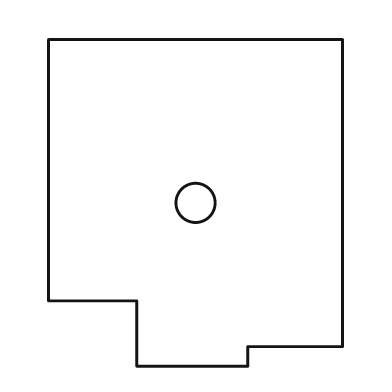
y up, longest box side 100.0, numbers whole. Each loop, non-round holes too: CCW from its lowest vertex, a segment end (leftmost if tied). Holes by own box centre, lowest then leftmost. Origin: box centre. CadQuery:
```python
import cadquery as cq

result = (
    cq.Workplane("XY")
    .moveTo(-18.0, -50.0)
    .lineTo(16.0, -50.0)
    .lineTo(16.0, -44.0)
    .lineTo(45.0, -44.0)
    .lineTo(45.0, 50.0)
    .lineTo(-45.0, 50.0)
    .lineTo(-45.0, -30.0)
    .lineTo(-18.0, -30.0)
    .close()
    .moveTo(0.0, 0.0)
    .circle(6.0)
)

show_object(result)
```